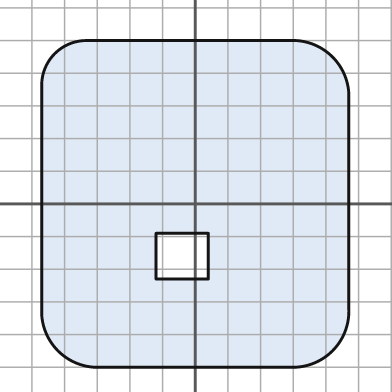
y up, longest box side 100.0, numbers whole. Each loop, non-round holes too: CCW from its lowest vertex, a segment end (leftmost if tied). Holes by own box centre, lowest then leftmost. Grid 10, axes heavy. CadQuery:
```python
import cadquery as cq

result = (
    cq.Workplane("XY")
    .moveTo(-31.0, -50.0)
    .lineTo(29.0, -50.0)
    .threePointArc((42.0, -45.0), (47.0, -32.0))
    .lineTo(47.0, 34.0)
    .threePointArc((42.0, 45.0), (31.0, 50.0))
    .lineTo(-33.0, 50.0)
    .threePointArc((-43.0, 46.0), (-47.0, 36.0))
    .lineTo(-47.0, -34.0)
    .threePointArc((-42.0, -45.0), (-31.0, -50.0))
    .close()
    .moveTo(-12.0, -23.0)
    .lineTo(4.0, -23.0)
    .lineTo(4.0, -9.0)
    .lineTo(-12.0, -9.0)
    .close()
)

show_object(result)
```